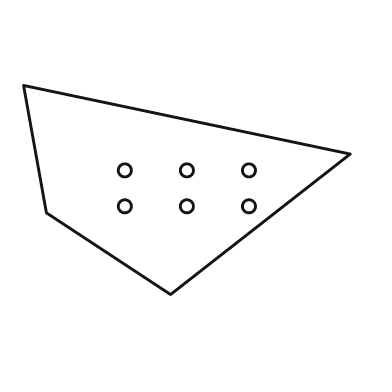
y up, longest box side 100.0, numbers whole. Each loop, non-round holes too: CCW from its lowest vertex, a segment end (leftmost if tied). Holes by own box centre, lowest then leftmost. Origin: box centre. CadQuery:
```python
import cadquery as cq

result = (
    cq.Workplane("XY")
    .moveTo(-5.0, -32.0)
    .lineTo(50.0, 11.0)
    .lineTo(-50.0, 32.0)
    .lineTo(-43.0, -7.0)
    .close()
    .moveTo(-19.0, -5.0)
    .circle(2.0)
    .moveTo(0.0, -5.0)
    .circle(2.0)
    .moveTo(19.0, -5.0)
    .circle(2.0)
    .moveTo(-19.0, 6.0)
    .circle(2.0)
    .moveTo(0.0, 6.0)
    .circle(2.0)
    .moveTo(19.0, 6.0)
    .circle(2.0)
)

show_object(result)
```